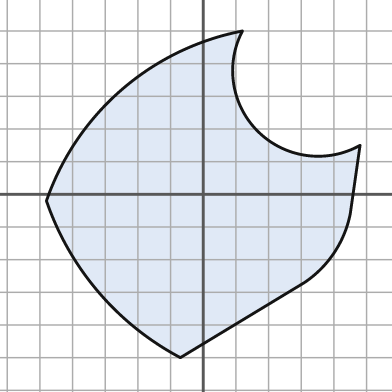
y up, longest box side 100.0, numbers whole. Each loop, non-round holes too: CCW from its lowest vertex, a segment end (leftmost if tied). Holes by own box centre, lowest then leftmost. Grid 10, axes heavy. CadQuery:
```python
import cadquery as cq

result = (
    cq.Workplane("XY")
    .moveTo(-7.0, -50.0)
    .lineTo(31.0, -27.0)
    .threePointArc((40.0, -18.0), (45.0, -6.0))
    .lineTo(48.0, 15.0)
    .threePointArc((17.0, 19.0), (12.0, 50.0))
    .threePointArc((-25.0, 32.0), (-48.0, -2.0))
    .threePointArc((-32.0, -30.0), (-7.0, -50.0))
    .close()
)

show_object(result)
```